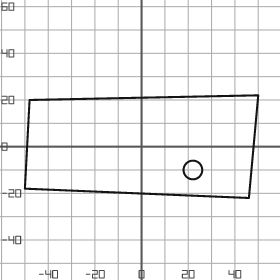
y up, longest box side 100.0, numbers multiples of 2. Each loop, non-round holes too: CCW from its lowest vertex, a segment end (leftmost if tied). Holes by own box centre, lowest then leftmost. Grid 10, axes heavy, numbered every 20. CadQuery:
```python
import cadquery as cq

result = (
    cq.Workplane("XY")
    .moveTo(46.0, -22.0)
    .lineTo(50.0, 22.0)
    .lineTo(-48.0, 20.0)
    .lineTo(-50.0, -18.0)
    .close()
    .moveTo(22.0, -10.0)
    .circle(4.0)
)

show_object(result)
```